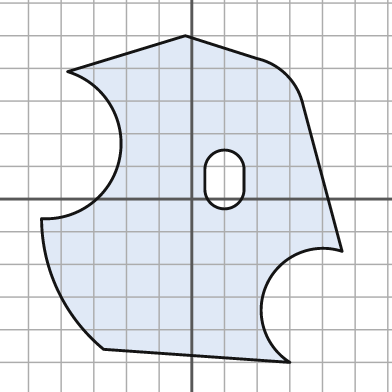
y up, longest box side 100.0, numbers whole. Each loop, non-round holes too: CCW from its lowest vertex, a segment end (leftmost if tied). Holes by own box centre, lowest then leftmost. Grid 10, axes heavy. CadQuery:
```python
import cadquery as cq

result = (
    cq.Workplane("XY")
    .moveTo(30.0, -50.0)
    .threePointArc((23.0, -26.0), (46.0, -16.0))
    .lineTo(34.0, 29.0)
    .threePointArc((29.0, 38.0), (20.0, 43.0))
    .lineTo(-2.0, 50.0)
    .lineTo(-38.0, 39.0)
    .threePointArc((-22.0, 13.0), (-46.0, -6.0))
    .threePointArc((-41.0, -28.0), (-27.0, -46.0))
    .close()
    .moveTo(4.0, 3.0)
    .threePointArc((10.0, -3.0), (16.0, 3.0))
    .lineTo(16.0, 9.0)
    .threePointArc((10.0, 15.0), (4.0, 9.0))
    .close()
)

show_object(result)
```